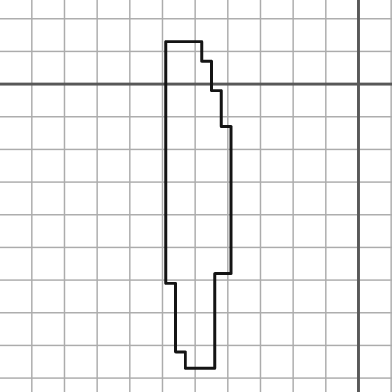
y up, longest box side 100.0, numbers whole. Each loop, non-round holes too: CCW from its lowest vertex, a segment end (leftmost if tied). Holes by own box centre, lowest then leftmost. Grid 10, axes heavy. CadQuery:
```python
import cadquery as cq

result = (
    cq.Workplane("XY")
    .moveTo(-53.0, -87.0)
    .lineTo(-44.0, -87.0)
    .lineTo(-44.0, -58.0)
    .lineTo(-39.0, -58.0)
    .lineTo(-39.0, -13.0)
    .lineTo(-42.0, -13.0)
    .lineTo(-42.0, -2.0)
    .lineTo(-45.0, -2.0)
    .lineTo(-45.0, 7.0)
    .lineTo(-48.0, 7.0)
    .lineTo(-48.0, 13.0)
    .lineTo(-59.0, 13.0)
    .lineTo(-59.0, -61.0)
    .lineTo(-56.0, -61.0)
    .lineTo(-56.0, -82.0)
    .lineTo(-53.0, -82.0)
    .close()
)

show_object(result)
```